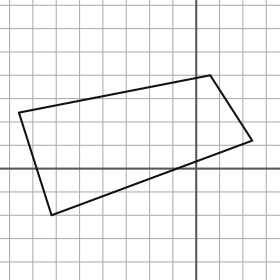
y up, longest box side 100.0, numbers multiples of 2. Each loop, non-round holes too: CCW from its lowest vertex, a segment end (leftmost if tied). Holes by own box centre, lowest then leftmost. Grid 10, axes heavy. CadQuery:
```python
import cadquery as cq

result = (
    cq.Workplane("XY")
    .moveTo(-62.0, -20.0)
    .lineTo(24.0, 12.0)
    .lineTo(6.0, 40.0)
    .lineTo(-76.0, 24.0)
    .close()
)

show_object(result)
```